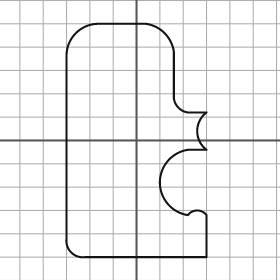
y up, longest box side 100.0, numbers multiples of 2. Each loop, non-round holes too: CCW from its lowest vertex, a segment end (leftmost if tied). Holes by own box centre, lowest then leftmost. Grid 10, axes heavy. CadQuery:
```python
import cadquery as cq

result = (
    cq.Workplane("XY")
    .moveTo(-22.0, -50.0)
    .lineTo(30.0, -50.0)
    .lineTo(30.0, -32.0)
    .threePointArc((26.0, -30.0), (22.0, -32.0))
    .threePointArc((10.0, -18.0), (22.0, -4.0))
    .lineTo(30.0, -4.0)
    .threePointArc((26.0, 4.0), (30.0, 12.0))
    .lineTo(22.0, 12.0)
    .threePointArc((18.0, 14.0), (16.0, 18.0))
    .lineTo(16.0, 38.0)
    .threePointArc((12.0, 46.0), (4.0, 50.0))
    .lineTo(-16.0, 50.0)
    .threePointArc((-26.0, 46.0), (-30.0, 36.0))
    .lineTo(-30.0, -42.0)
    .threePointArc((-28.0, -48.0), (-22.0, -50.0))
    .close()
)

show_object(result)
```